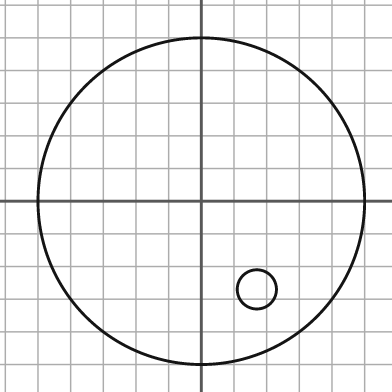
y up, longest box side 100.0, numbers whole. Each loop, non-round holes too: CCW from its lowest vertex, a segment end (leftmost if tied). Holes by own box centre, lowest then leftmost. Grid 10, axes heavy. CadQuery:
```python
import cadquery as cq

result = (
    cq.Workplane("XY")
    .moveTo(0.0, 0.0)
    .circle(50.0)
    .moveTo(17.0, -27.0)
    .circle(6.0)
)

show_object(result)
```